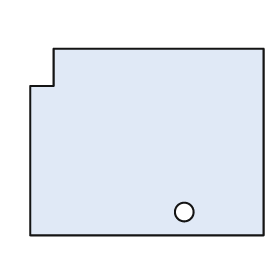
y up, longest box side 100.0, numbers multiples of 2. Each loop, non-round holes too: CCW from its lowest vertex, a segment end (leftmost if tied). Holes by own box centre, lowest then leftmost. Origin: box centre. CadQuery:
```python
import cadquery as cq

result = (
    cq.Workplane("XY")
    .moveTo(-50.0, -40.0)
    .lineTo(50.0, -40.0)
    .lineTo(50.0, 40.0)
    .lineTo(-40.0, 40.0)
    .lineTo(-40.0, 24.0)
    .lineTo(-50.0, 24.0)
    .close()
    .moveTo(16.0, -30.0)
    .circle(4.0)
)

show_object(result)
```